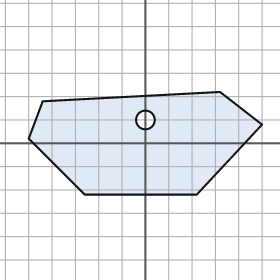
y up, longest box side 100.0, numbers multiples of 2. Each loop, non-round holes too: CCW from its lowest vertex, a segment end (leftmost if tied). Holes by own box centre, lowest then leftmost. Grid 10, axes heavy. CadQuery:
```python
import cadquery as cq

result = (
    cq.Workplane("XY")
    .moveTo(-26.0, -22.0)
    .lineTo(22.0, -22.0)
    .lineTo(50.0, 8.0)
    .lineTo(32.0, 22.0)
    .lineTo(-44.0, 18.0)
    .lineTo(-50.0, 2.0)
    .close()
    .moveTo(0.0, 10.0)
    .circle(4.0)
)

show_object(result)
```